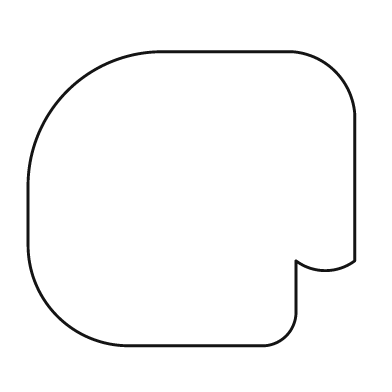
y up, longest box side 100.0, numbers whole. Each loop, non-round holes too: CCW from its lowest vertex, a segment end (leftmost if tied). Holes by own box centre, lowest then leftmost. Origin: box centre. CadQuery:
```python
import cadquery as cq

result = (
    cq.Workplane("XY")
    .moveTo(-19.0, -45.0)
    .lineTo(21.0, -45.0)
    .threePointArc((29.0, -42.0), (32.0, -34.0))
    .lineTo(32.0, -19.0)
    .threePointArc((41.0, -22.0), (50.0, -19.0))
    .lineTo(50.0, 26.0)
    .threePointArc((44.0, 39.0), (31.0, 45.0))
    .lineTo(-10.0, 45.0)
    .threePointArc((-38.0, 33.0), (-50.0, 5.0))
    .lineTo(-50.0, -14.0)
    .threePointArc((-41.0, -36.0), (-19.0, -45.0))
    .close()
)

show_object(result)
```